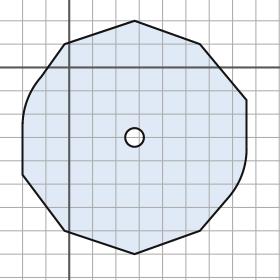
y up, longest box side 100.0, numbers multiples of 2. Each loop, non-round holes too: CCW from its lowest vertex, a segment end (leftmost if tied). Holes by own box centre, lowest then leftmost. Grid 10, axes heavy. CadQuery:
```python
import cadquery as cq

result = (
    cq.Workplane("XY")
    .moveTo(28.0, -80.0)
    .lineTo(56.0, -70.0)
    .lineTo(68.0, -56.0)
    .threePointArc((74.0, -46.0), (76.0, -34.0))
    .lineTo(76.0, -14.0)
    .lineTo(56.0, 10.0)
    .lineTo(28.0, 20.0)
    .lineTo(-2.0, 10.0)
    .lineTo(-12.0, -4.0)
    .threePointArc((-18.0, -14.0), (-20.0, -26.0))
    .lineTo(-20.0, -46.0)
    .lineTo(-2.0, -70.0)
    .close()
    .moveTo(28.0, -30.0)
    .circle(4.0)
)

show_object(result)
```